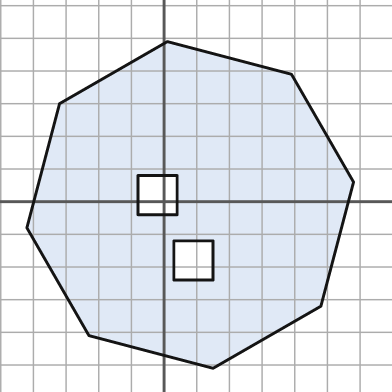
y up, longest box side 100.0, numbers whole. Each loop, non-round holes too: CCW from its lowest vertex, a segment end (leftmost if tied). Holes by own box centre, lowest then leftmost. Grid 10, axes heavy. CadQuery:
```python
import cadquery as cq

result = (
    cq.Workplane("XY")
    .moveTo(15.0, -51.0)
    .lineTo(48.0, -32.0)
    .lineTo(58.0, 6.0)
    .lineTo(39.0, 39.0)
    .lineTo(1.0, 49.0)
    .lineTo(-32.0, 30.0)
    .lineTo(-42.0, -8.0)
    .lineTo(-23.0, -41.0)
    .close()
    .moveTo(3.0, -24.0)
    .lineTo(15.0, -24.0)
    .lineTo(15.0, -12.0)
    .lineTo(3.0, -12.0)
    .close()
    .moveTo(-8.0, -4.0)
    .lineTo(4.0, -4.0)
    .lineTo(4.0, 8.0)
    .lineTo(-8.0, 8.0)
    .close()
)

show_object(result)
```